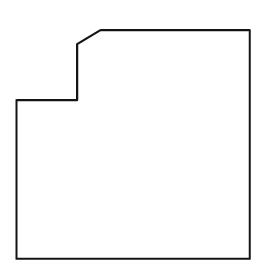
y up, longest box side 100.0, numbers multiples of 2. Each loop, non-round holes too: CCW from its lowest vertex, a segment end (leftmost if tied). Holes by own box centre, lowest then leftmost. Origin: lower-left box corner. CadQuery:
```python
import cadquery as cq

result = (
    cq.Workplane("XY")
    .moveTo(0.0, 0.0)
    .lineTo(100.0, 0.0)
    .lineTo(100.0, 98.0)
    .lineTo(36.0, 98.0)
    .lineTo(26.0, 92.0)
    .lineTo(26.0, 68.0)
    .lineTo(0.0, 68.0)
    .close()
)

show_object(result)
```